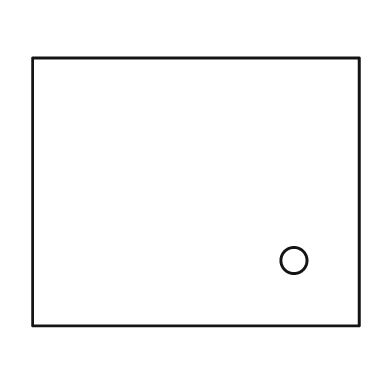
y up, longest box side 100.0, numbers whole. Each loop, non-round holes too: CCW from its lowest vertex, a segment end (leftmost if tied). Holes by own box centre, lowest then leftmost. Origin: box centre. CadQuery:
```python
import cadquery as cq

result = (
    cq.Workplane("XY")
    .moveTo(-50.0, -41.0)
    .lineTo(50.0, -41.0)
    .lineTo(50.0, 41.0)
    .lineTo(-50.0, 41.0)
    .close()
    .moveTo(30.0, -21.0)
    .circle(4.0)
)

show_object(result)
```